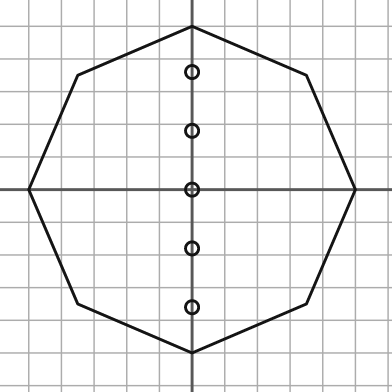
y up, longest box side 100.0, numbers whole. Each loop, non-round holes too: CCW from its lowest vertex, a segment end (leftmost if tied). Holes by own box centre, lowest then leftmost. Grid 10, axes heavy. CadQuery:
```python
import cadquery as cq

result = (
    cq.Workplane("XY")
    .moveTo(0.0, -50.0)
    .lineTo(35.0, -35.0)
    .lineTo(50.0, 0.0)
    .lineTo(35.0, 35.0)
    .lineTo(0.0, 50.0)
    .lineTo(-35.0, 35.0)
    .lineTo(-50.0, 0.0)
    .lineTo(-35.0, -35.0)
    .close()
    .moveTo(0.0, -36.0)
    .circle(2.0)
    .moveTo(0.0, -18.0)
    .circle(2.0)
    .moveTo(0.0, 0.0)
    .circle(2.0)
    .moveTo(0.0, 18.0)
    .circle(2.0)
    .moveTo(0.0, 36.0)
    .circle(2.0)
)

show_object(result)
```